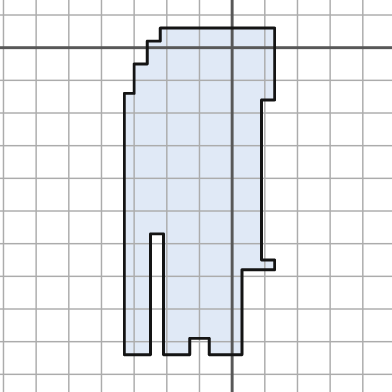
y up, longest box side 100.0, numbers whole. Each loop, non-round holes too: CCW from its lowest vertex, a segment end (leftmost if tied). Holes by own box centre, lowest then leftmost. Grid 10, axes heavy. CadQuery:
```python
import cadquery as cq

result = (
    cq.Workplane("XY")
    .moveTo(-33.0, -94.0)
    .lineTo(-25.0, -94.0)
    .lineTo(-25.0, -57.0)
    .lineTo(-21.0, -57.0)
    .lineTo(-21.0, -94.0)
    .lineTo(-13.0, -94.0)
    .lineTo(-13.0, -89.0)
    .lineTo(-7.0, -89.0)
    .lineTo(-7.0, -94.0)
    .lineTo(3.0, -94.0)
    .lineTo(3.0, -68.0)
    .lineTo(13.0, -68.0)
    .lineTo(13.0, -65.0)
    .lineTo(9.0, -65.0)
    .lineTo(9.0, -16.0)
    .lineTo(13.0, -16.0)
    .lineTo(13.0, 6.0)
    .lineTo(-22.0, 6.0)
    .lineTo(-22.0, 2.0)
    .lineTo(-26.0, 2.0)
    .lineTo(-26.0, -5.0)
    .lineTo(-30.0, -5.0)
    .lineTo(-30.0, -14.0)
    .lineTo(-33.0, -14.0)
    .close()
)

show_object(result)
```